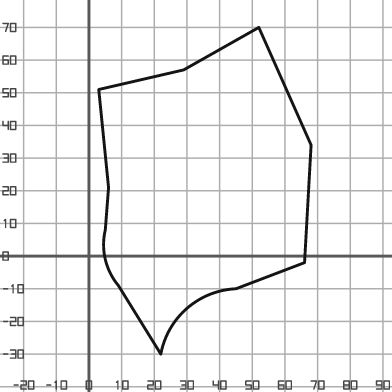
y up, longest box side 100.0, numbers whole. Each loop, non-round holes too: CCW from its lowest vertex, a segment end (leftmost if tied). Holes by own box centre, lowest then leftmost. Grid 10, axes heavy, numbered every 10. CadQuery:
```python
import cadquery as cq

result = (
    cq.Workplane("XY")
    .moveTo(22.0, -30.0)
    .threePointArc((30.0, -16.0), (45.0, -10.0))
    .lineTo(66.0, -2.0)
    .lineTo(68.0, 34.0)
    .lineTo(52.0, 70.0)
    .lineTo(29.0, 57.0)
    .lineTo(3.0, 51.0)
    .lineTo(6.0, 21.0)
    .lineTo(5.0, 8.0)
    .threePointArc((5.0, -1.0), (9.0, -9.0))
    .close()
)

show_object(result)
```